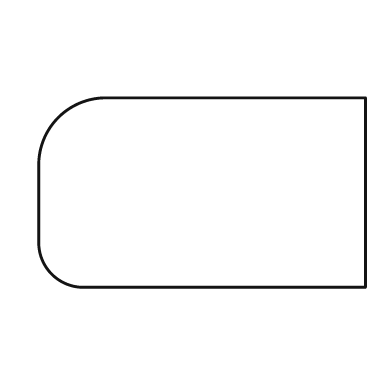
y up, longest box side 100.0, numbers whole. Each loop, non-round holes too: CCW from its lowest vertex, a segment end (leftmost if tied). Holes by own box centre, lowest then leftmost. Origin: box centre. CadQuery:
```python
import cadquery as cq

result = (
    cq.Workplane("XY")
    .moveTo(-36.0, -29.0)
    .lineTo(50.0, -29.0)
    .lineTo(50.0, 29.0)
    .lineTo(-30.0, 29.0)
    .threePointArc((-44.0, 23.0), (-50.0, 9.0))
    .lineTo(-50.0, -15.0)
    .threePointArc((-46.0, -25.0), (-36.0, -29.0))
    .close()
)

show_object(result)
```